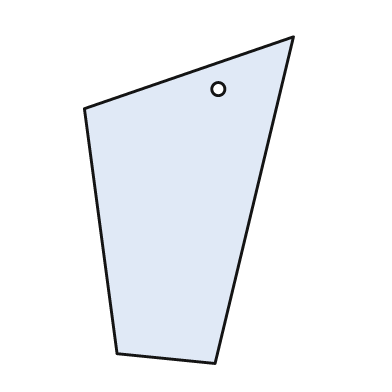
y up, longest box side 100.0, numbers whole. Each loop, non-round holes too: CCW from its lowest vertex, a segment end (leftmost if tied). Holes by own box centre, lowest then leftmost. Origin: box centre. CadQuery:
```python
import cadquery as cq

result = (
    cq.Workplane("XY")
    .moveTo(8.0, -50.0)
    .lineTo(32.0, 50.0)
    .lineTo(-32.0, 28.0)
    .lineTo(-22.0, -47.0)
    .close()
    .moveTo(9.0, 34.0)
    .circle(2.0)
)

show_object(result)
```